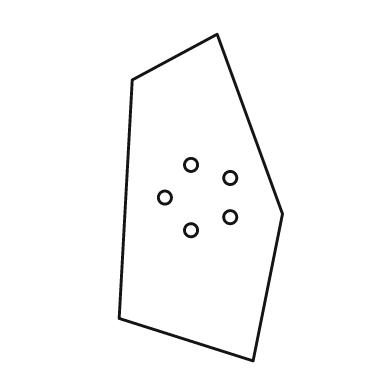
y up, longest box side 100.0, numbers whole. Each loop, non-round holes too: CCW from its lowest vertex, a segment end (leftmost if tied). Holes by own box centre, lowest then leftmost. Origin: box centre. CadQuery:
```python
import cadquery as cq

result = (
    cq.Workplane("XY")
    .moveTo(16.0, -50.0)
    .lineTo(25.0, -5.0)
    .lineTo(5.0, 50.0)
    .lineTo(-21.0, 36.0)
    .lineTo(-25.0, -37.0)
    .close()
    .moveTo(-3.0, -10.0)
    .circle(2.0)
    .moveTo(9.0, -6.0)
    .circle(2.0)
    .moveTo(-11.0, 0.0)
    .circle(2.0)
    .moveTo(9.0, 6.0)
    .circle(2.0)
    .moveTo(-3.0, 10.0)
    .circle(2.0)
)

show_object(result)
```